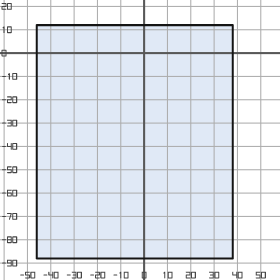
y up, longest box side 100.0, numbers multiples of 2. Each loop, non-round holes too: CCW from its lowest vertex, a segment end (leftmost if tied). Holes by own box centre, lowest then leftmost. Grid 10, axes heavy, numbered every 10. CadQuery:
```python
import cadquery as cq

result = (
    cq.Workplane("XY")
    .moveTo(-46.0, -88.0)
    .lineTo(38.0, -88.0)
    .lineTo(38.0, 12.0)
    .lineTo(-46.0, 12.0)
    .close()
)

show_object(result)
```